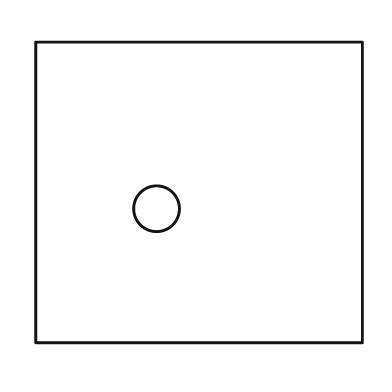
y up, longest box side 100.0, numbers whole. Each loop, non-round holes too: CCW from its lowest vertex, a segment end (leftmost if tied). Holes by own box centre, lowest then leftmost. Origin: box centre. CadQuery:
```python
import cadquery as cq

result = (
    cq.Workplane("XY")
    .moveTo(-50.0, -46.0)
    .lineTo(50.0, -46.0)
    .lineTo(50.0, 46.0)
    .lineTo(-50.0, 46.0)
    .close()
    .moveTo(-13.0, -5.0)
    .circle(7.0)
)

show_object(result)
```